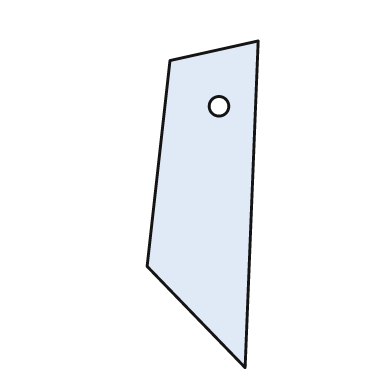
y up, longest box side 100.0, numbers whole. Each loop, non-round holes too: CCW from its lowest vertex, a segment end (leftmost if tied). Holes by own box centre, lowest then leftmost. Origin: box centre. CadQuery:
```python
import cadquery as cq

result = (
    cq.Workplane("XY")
    .moveTo(13.0, -50.0)
    .lineTo(17.0, 50.0)
    .lineTo(-10.0, 44.0)
    .lineTo(-17.0, -19.0)
    .close()
    .moveTo(5.0, 30.0)
    .circle(3.0)
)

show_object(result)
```